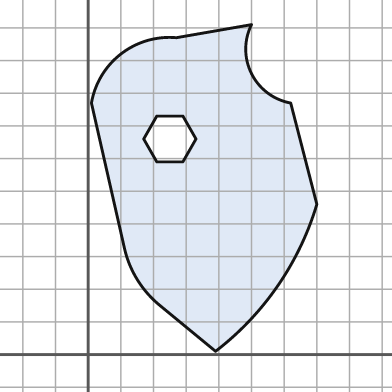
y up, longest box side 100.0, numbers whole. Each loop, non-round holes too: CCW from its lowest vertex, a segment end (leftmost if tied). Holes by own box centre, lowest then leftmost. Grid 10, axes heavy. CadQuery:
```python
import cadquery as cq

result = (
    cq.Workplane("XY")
    .moveTo(39.0, 1.0)
    .threePointArc((58.0, 21.0), (70.0, 46.0))
    .lineTo(62.0, 77.0)
    .threePointArc((50.0, 86.0), (50.0, 101.0))
    .lineTo(27.0, 97.0)
    .threePointArc((10.0, 92.0), (1.0, 77.0))
    .lineTo(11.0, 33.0)
    .threePointArc((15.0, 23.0), (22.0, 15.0))
    .close()
    .moveTo(21.0, 59.0)
    .lineTo(29.0, 59.0)
    .lineTo(33.0, 66.0)
    .lineTo(29.0, 73.0)
    .lineTo(21.0, 73.0)
    .lineTo(17.0, 66.0)
    .close()
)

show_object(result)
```